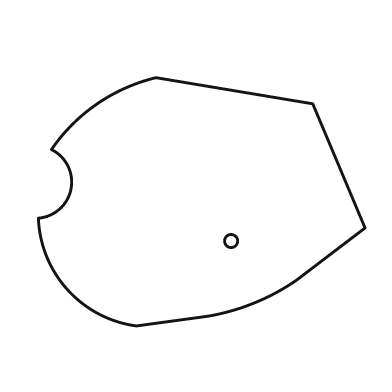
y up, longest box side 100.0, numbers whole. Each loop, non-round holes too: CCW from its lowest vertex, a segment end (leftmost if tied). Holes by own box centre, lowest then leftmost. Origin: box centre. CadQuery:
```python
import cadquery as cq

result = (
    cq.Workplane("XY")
    .moveTo(-20.0, -38.0)
    .lineTo(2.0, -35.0)
    .threePointArc((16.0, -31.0), (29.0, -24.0))
    .lineTo(50.0, -8.0)
    .lineTo(34.0, 30.0)
    .lineTo(-14.0, 38.0)
    .threePointArc((-32.0, 30.0), (-46.0, 16.0))
    .threePointArc((-40.0, 4.0), (-50.0, -5.0))
    .threePointArc((-41.0, -27.0), (-20.0, -38.0))
    .close()
    .moveTo(9.0, -12.0)
    .circle(2.0)
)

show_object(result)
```